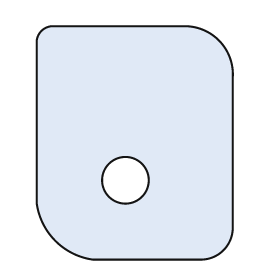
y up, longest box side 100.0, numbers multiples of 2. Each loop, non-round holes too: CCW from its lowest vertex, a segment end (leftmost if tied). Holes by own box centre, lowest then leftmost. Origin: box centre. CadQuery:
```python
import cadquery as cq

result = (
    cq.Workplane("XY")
    .moveTo(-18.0, -50.0)
    .lineTo(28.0, -50.0)
    .threePointArc((38.0, -46.0), (42.0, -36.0))
    .lineTo(42.0, 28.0)
    .threePointArc((36.0, 44.0), (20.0, 50.0))
    .lineTo(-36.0, 50.0)
    .threePointArc((-40.0, 48.0), (-42.0, 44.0))
    .lineTo(-42.0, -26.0)
    .threePointArc((-34.0, -42.0), (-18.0, -50.0))
    .close()
    .moveTo(-4.0, -16.0)
    .circle(10.0)
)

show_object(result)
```